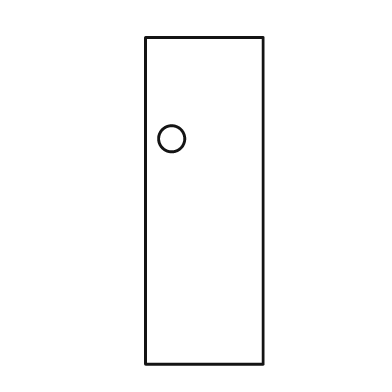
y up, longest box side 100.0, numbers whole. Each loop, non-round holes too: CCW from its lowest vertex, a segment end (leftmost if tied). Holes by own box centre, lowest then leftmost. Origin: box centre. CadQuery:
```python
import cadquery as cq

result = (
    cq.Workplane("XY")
    .moveTo(-18.0, -50.0)
    .lineTo(18.0, -50.0)
    .lineTo(18.0, 50.0)
    .lineTo(-18.0, 50.0)
    .close()
    .moveTo(-10.0, 19.0)
    .circle(4.0)
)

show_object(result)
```